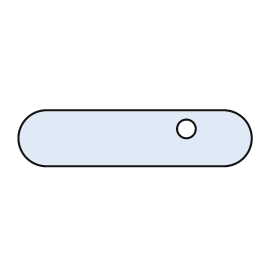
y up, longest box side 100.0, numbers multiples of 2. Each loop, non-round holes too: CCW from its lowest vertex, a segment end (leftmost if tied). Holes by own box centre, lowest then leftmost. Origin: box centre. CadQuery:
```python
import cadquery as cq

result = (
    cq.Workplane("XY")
    .moveTo(-38.0, -12.0)
    .lineTo(38.0, -12.0)
    .threePointArc((50.0, 0.0), (38.0, 12.0))
    .lineTo(-38.0, 12.0)
    .threePointArc((-50.0, 0.0), (-38.0, -12.0))
    .close()
    .moveTo(22.0, 4.0)
    .circle(4.0)
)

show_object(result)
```